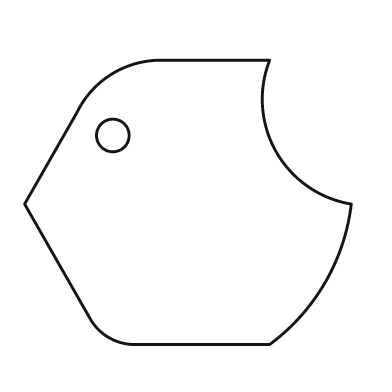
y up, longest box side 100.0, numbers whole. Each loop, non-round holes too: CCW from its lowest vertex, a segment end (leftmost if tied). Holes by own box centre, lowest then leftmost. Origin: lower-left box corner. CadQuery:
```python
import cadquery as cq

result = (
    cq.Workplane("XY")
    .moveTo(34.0, 0.0)
    .lineTo(75.0, 0.0)
    .threePointArc((92.0, 19.0), (100.0, 43.0))
    .threePointArc((77.0, 59.0), (75.0, 87.0))
    .lineTo(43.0, 87.0)
    .threePointArc((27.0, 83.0), (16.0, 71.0))
    .lineTo(0.0, 43.0)
    .lineTo(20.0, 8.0)
    .threePointArc((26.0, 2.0), (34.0, 0.0))
    .close()
    .moveTo(27.0, 64.0)
    .circle(5.0)
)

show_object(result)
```